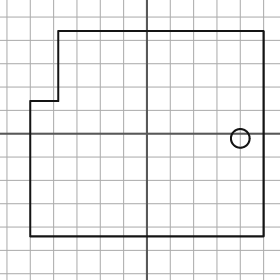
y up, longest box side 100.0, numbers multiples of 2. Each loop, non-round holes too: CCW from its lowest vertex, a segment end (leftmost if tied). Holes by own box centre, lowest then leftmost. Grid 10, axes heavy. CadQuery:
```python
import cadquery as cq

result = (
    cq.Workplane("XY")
    .moveTo(-50.0, -44.0)
    .lineTo(50.0, -44.0)
    .lineTo(50.0, 44.0)
    .lineTo(-38.0, 44.0)
    .lineTo(-38.0, 14.0)
    .lineTo(-50.0, 14.0)
    .close()
    .moveTo(40.0, -2.0)
    .circle(4.0)
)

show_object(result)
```